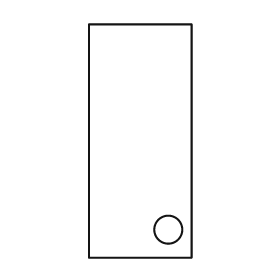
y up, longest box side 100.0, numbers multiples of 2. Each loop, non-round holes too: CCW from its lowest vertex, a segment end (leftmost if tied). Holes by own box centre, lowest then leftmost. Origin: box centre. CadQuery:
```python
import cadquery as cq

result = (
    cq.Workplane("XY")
    .moveTo(-22.0, -50.0)
    .lineTo(22.0, -50.0)
    .lineTo(22.0, 50.0)
    .lineTo(-22.0, 50.0)
    .close()
    .moveTo(12.0, -38.0)
    .circle(6.0)
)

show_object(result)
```